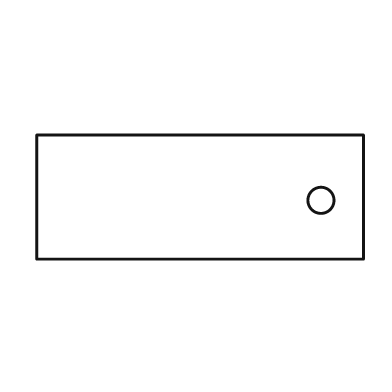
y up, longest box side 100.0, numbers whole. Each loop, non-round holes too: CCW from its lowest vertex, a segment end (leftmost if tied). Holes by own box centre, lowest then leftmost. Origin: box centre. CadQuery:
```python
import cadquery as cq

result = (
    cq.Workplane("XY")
    .moveTo(-50.0, -19.0)
    .lineTo(50.0, -19.0)
    .lineTo(50.0, 19.0)
    .lineTo(-50.0, 19.0)
    .close()
    .moveTo(37.0, -1.0)
    .circle(4.0)
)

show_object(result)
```